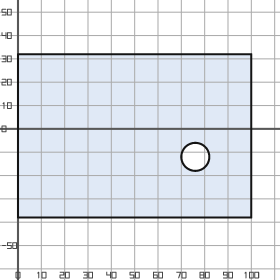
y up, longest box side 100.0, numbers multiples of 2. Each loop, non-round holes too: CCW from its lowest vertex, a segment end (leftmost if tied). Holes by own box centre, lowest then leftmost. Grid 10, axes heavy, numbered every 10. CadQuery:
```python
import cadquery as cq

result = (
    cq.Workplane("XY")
    .moveTo(0.0, -38.0)
    .lineTo(100.0, -38.0)
    .lineTo(100.0, 32.0)
    .lineTo(0.0, 32.0)
    .close()
    .moveTo(76.0, -12.0)
    .circle(6.0)
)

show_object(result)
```